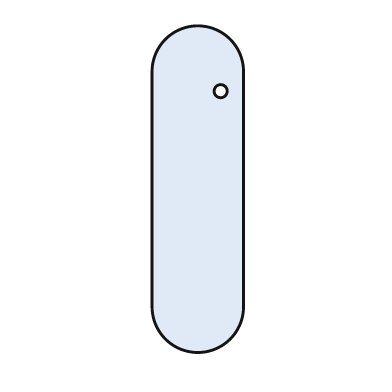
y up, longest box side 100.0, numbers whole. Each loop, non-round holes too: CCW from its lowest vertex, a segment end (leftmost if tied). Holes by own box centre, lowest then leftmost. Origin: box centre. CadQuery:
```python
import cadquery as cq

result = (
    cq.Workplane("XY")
    .moveTo(-14.0, -36.0)
    .threePointArc((0.0, -50.0), (14.0, -36.0))
    .lineTo(14.0, 36.0)
    .threePointArc((0.0, 50.0), (-14.0, 36.0))
    .close()
    .moveTo(7.0, 30.0)
    .circle(2.0)
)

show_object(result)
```